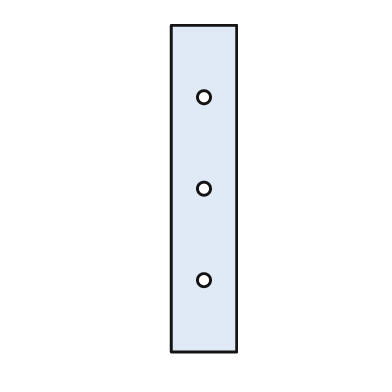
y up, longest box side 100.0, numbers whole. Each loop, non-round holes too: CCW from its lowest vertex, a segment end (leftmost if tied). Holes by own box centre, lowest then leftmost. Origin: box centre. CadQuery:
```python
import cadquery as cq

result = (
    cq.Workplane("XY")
    .moveTo(-10.0, -50.0)
    .lineTo(10.0, -50.0)
    .lineTo(10.0, 50.0)
    .lineTo(-10.0, 50.0)
    .close()
    .moveTo(0.0, -28.0)
    .circle(2.0)
    .moveTo(0.0, 0.0)
    .circle(2.0)
    .moveTo(0.0, 28.0)
    .circle(2.0)
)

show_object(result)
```